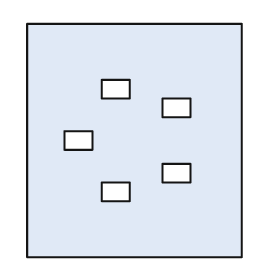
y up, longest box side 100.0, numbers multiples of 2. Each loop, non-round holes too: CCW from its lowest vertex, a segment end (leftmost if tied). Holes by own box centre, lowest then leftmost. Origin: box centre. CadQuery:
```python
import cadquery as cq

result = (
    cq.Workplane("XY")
    .moveTo(-46.0, -50.0)
    .lineTo(46.0, -50.0)
    .lineTo(46.0, 50.0)
    .lineTo(-46.0, 50.0)
    .close()
    .moveTo(-14.0, -26.0)
    .lineTo(-2.0, -26.0)
    .lineTo(-2.0, -18.0)
    .lineTo(-14.0, -18.0)
    .close()
    .moveTo(12.0, -18.0)
    .lineTo(24.0, -18.0)
    .lineTo(24.0, -10.0)
    .lineTo(12.0, -10.0)
    .close()
    .moveTo(-30.0, -4.0)
    .lineTo(-18.0, -4.0)
    .lineTo(-18.0, 4.0)
    .lineTo(-30.0, 4.0)
    .close()
    .moveTo(12.0, 10.0)
    .lineTo(24.0, 10.0)
    .lineTo(24.0, 18.0)
    .lineTo(12.0, 18.0)
    .close()
    .moveTo(-14.0, 18.0)
    .lineTo(-2.0, 18.0)
    .lineTo(-2.0, 26.0)
    .lineTo(-14.0, 26.0)
    .close()
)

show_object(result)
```